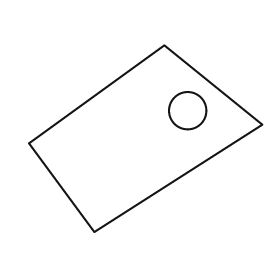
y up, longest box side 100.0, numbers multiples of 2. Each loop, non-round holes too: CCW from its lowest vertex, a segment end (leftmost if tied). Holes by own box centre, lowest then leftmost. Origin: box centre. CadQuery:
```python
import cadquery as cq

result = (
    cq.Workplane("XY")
    .moveTo(-22.0, -40.0)
    .lineTo(50.0, 6.0)
    .lineTo(8.0, 40.0)
    .lineTo(-50.0, -2.0)
    .close()
    .moveTo(18.0, 12.0)
    .circle(8.0)
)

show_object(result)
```